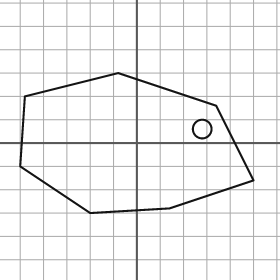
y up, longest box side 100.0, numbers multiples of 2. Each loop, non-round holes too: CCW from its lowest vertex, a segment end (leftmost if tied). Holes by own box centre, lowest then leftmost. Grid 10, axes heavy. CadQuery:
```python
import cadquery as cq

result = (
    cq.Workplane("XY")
    .moveTo(-20.0, -30.0)
    .lineTo(14.0, -28.0)
    .lineTo(50.0, -16.0)
    .lineTo(34.0, 16.0)
    .lineTo(-8.0, 30.0)
    .lineTo(-48.0, 20.0)
    .lineTo(-50.0, -10.0)
    .close()
    .moveTo(28.0, 6.0)
    .circle(4.0)
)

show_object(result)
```